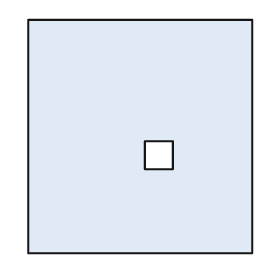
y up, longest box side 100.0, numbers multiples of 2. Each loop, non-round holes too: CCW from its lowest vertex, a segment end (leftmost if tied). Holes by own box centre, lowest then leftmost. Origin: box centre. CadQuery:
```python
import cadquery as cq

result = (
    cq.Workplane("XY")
    .moveTo(-48.0, -50.0)
    .lineTo(48.0, -50.0)
    .lineTo(48.0, 50.0)
    .lineTo(-48.0, 50.0)
    .close()
    .moveTo(2.0, -14.0)
    .lineTo(14.0, -14.0)
    .lineTo(14.0, -2.0)
    .lineTo(2.0, -2.0)
    .close()
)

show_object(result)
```